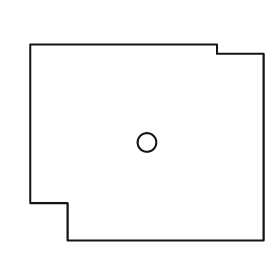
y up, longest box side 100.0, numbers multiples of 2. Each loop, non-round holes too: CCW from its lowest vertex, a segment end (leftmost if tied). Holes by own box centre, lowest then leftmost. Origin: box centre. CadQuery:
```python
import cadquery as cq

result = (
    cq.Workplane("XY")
    .moveTo(-34.0, -42.0)
    .lineTo(50.0, -42.0)
    .lineTo(50.0, 38.0)
    .lineTo(30.0, 38.0)
    .lineTo(30.0, 42.0)
    .lineTo(-50.0, 42.0)
    .lineTo(-50.0, -26.0)
    .lineTo(-34.0, -26.0)
    .close()
    .moveTo(0.0, 0.0)
    .circle(4.0)
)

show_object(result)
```